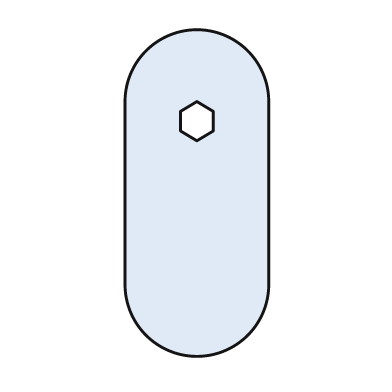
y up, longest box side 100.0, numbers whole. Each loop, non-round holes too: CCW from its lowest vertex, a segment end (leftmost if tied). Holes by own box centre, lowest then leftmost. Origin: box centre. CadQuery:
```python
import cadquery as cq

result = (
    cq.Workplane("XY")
    .moveTo(-22.0, -28.0)
    .threePointArc((0.0, -50.0), (22.0, -28.0))
    .lineTo(22.0, 28.0)
    .threePointArc((0.0, 50.0), (-22.0, 28.0))
    .close()
    .moveTo(0.0, 16.0)
    .lineTo(5.0, 19.0)
    .lineTo(5.0, 25.0)
    .lineTo(0.0, 28.0)
    .lineTo(-5.0, 25.0)
    .lineTo(-5.0, 19.0)
    .close()
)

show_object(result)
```